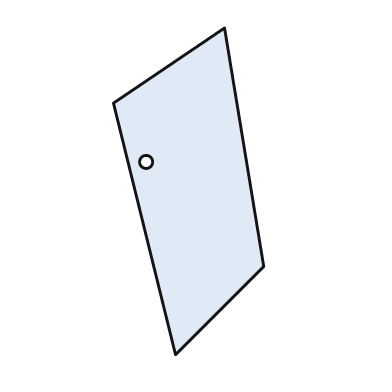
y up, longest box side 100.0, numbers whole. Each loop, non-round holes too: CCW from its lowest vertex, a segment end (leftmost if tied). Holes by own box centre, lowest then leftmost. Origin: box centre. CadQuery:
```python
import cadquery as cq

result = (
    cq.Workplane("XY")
    .moveTo(-4.0, -50.0)
    .lineTo(23.0, -23.0)
    .lineTo(11.0, 50.0)
    .lineTo(-23.0, 27.0)
    .close()
    .moveTo(-13.0, 9.0)
    .circle(2.0)
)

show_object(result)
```